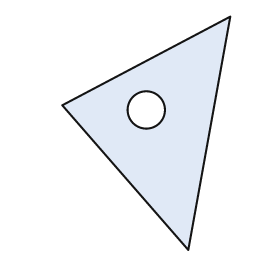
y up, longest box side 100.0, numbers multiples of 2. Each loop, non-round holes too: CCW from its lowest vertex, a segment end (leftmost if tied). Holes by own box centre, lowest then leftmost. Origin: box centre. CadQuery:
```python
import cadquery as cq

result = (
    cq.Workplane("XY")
    .moveTo(18.0, -50.0)
    .lineTo(36.0, 50.0)
    .lineTo(-36.0, 12.0)
    .close()
    .moveTo(0.0, 10.0)
    .circle(8.0)
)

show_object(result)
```